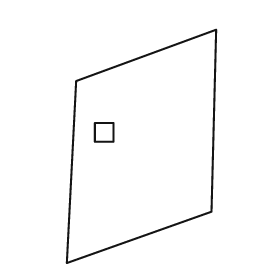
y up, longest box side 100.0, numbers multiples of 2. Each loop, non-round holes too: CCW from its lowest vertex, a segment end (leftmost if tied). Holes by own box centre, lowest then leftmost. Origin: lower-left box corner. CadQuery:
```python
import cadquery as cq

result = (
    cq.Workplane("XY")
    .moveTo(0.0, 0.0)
    .lineTo(62.0, 22.0)
    .lineTo(64.0, 100.0)
    .lineTo(4.0, 78.0)
    .close()
    .moveTo(12.0, 52.0)
    .lineTo(20.0, 52.0)
    .lineTo(20.0, 60.0)
    .lineTo(12.0, 60.0)
    .close()
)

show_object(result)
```